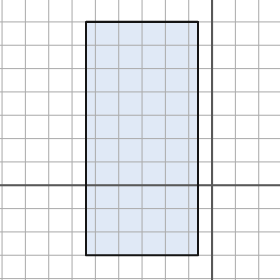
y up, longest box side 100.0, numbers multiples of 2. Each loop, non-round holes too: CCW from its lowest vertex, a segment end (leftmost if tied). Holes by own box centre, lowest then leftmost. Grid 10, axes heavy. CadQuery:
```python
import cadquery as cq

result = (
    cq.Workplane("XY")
    .moveTo(-54.0, -30.0)
    .lineTo(-6.0, -30.0)
    .lineTo(-6.0, 70.0)
    .lineTo(-54.0, 70.0)
    .close()
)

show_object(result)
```